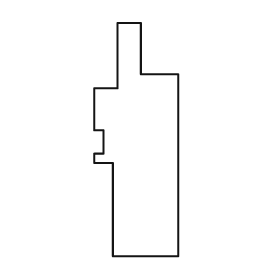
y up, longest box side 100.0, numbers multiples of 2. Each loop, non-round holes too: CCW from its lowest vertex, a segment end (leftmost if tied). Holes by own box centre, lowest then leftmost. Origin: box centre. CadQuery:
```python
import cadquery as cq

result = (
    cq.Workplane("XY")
    .moveTo(-10.0, -50.0)
    .lineTo(18.0, -50.0)
    .lineTo(18.0, 28.0)
    .lineTo(2.0, 28.0)
    .lineTo(2.0, 50.0)
    .lineTo(-8.0, 50.0)
    .lineTo(-8.0, 22.0)
    .lineTo(-18.0, 22.0)
    .lineTo(-18.0, 4.0)
    .lineTo(-14.0, 4.0)
    .lineTo(-14.0, -6.0)
    .lineTo(-18.0, -6.0)
    .lineTo(-18.0, -10.0)
    .lineTo(-10.0, -10.0)
    .close()
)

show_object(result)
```